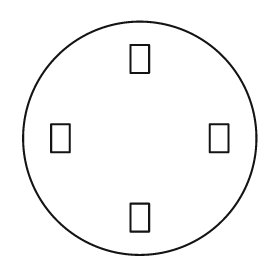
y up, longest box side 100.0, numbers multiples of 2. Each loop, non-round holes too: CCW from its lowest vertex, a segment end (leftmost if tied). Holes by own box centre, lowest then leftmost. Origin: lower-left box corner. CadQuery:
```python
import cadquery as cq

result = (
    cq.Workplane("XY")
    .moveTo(50.0, 50.0)
    .circle(50.0)
    .moveTo(46.0, 10.0)
    .lineTo(54.0, 10.0)
    .lineTo(54.0, 22.0)
    .lineTo(46.0, 22.0)
    .close()
    .moveTo(12.0, 44.0)
    .lineTo(20.0, 44.0)
    .lineTo(20.0, 56.0)
    .lineTo(12.0, 56.0)
    .close()
    .moveTo(80.0, 44.0)
    .lineTo(88.0, 44.0)
    .lineTo(88.0, 56.0)
    .lineTo(80.0, 56.0)
    .close()
    .moveTo(46.0, 78.0)
    .lineTo(54.0, 78.0)
    .lineTo(54.0, 90.0)
    .lineTo(46.0, 90.0)
    .close()
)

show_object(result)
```